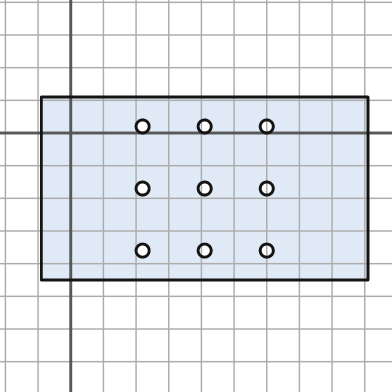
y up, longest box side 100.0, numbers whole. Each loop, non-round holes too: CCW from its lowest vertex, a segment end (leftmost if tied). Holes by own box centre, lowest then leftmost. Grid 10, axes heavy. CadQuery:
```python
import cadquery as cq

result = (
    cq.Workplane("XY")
    .moveTo(-9.0, -45.0)
    .lineTo(91.0, -45.0)
    .lineTo(91.0, 11.0)
    .lineTo(-9.0, 11.0)
    .close()
    .moveTo(22.0, -36.0)
    .circle(2.0)
    .moveTo(41.0, -36.0)
    .circle(2.0)
    .moveTo(60.0, -36.0)
    .circle(2.0)
    .moveTo(22.0, -17.0)
    .circle(2.0)
    .moveTo(41.0, -17.0)
    .circle(2.0)
    .moveTo(60.0, -17.0)
    .circle(2.0)
    .moveTo(22.0, 2.0)
    .circle(2.0)
    .moveTo(41.0, 2.0)
    .circle(2.0)
    .moveTo(60.0, 2.0)
    .circle(2.0)
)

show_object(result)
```